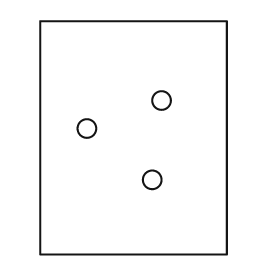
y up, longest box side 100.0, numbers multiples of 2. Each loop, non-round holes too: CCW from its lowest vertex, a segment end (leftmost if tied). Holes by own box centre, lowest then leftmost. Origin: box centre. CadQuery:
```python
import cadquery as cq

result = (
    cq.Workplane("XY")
    .moveTo(-40.0, -50.0)
    .lineTo(40.0, -50.0)
    .lineTo(40.0, 50.0)
    .lineTo(-40.0, 50.0)
    .close()
    .moveTo(8.0, -18.0)
    .circle(4.0)
    .moveTo(-20.0, 4.0)
    .circle(4.0)
    .moveTo(12.0, 16.0)
    .circle(4.0)
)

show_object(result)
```